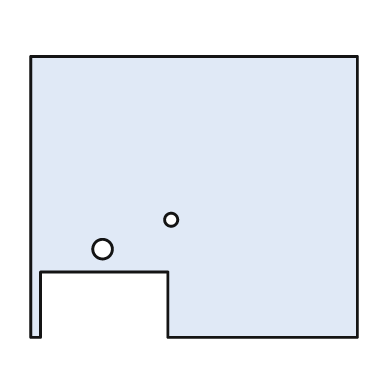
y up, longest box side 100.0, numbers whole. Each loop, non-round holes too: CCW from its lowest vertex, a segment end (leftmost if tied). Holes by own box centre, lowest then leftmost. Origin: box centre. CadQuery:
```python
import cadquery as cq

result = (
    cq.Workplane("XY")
    .moveTo(-50.0, -43.0)
    .lineTo(-47.0, -43.0)
    .lineTo(-47.0, -23.0)
    .lineTo(-8.0, -23.0)
    .lineTo(-8.0, -43.0)
    .lineTo(50.0, -43.0)
    .lineTo(50.0, 43.0)
    .lineTo(-50.0, 43.0)
    .close()
    .moveTo(-28.0, -16.0)
    .circle(3.0)
    .moveTo(-7.0, -7.0)
    .circle(2.0)
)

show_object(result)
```